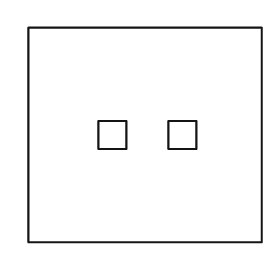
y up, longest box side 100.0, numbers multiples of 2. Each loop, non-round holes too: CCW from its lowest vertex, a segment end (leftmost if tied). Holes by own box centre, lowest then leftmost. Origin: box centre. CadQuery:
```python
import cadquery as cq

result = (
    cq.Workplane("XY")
    .moveTo(-50.0, -46.0)
    .lineTo(50.0, -46.0)
    .lineTo(50.0, 46.0)
    .lineTo(-50.0, 46.0)
    .close()
    .moveTo(-20.0, -6.0)
    .lineTo(-8.0, -6.0)
    .lineTo(-8.0, 6.0)
    .lineTo(-20.0, 6.0)
    .close()
    .moveTo(10.0, -6.0)
    .lineTo(22.0, -6.0)
    .lineTo(22.0, 6.0)
    .lineTo(10.0, 6.0)
    .close()
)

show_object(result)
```